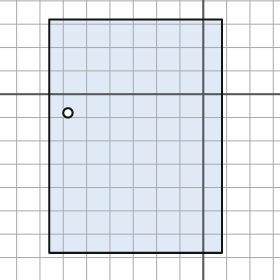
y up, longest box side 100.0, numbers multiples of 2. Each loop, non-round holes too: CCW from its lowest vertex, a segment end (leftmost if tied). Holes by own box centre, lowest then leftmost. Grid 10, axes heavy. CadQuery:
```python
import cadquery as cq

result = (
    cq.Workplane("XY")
    .moveTo(-66.0, -68.0)
    .lineTo(8.0, -68.0)
    .lineTo(8.0, 32.0)
    .lineTo(-66.0, 32.0)
    .close()
    .moveTo(-58.0, -8.0)
    .circle(2.0)
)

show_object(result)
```